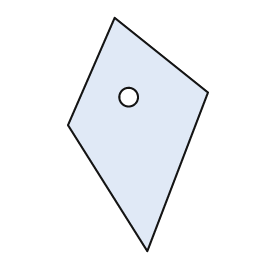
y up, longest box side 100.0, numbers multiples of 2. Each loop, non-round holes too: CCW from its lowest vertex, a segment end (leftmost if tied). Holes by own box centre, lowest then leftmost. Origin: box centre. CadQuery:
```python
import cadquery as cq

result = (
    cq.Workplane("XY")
    .moveTo(4.0, -50.0)
    .lineTo(30.0, 18.0)
    .lineTo(-10.0, 50.0)
    .lineTo(-30.0, 4.0)
    .close()
    .moveTo(-4.0, 16.0)
    .circle(4.0)
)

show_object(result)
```